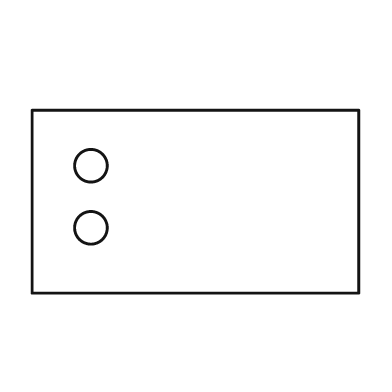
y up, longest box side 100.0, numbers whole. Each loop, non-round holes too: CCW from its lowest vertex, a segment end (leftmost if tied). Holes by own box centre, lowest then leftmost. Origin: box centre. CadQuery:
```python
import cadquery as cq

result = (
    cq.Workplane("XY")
    .moveTo(-50.0, -28.0)
    .lineTo(50.0, -28.0)
    .lineTo(50.0, 28.0)
    .lineTo(-50.0, 28.0)
    .close()
    .moveTo(-32.0, -8.0)
    .circle(5.0)
    .moveTo(-32.0, 11.0)
    .circle(5.0)
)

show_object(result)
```